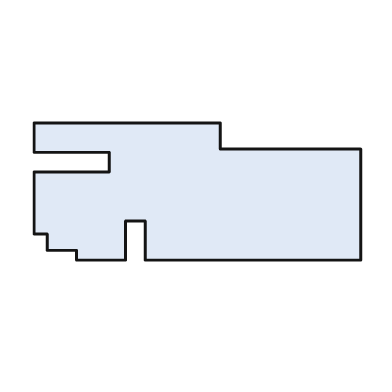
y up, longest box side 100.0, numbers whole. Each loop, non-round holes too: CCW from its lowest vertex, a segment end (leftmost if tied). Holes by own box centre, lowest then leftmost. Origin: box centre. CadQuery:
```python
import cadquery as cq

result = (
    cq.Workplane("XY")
    .moveTo(-37.0, -21.0)
    .lineTo(-22.0, -21.0)
    .lineTo(-22.0, -9.0)
    .lineTo(-16.0, -9.0)
    .lineTo(-16.0, -21.0)
    .lineTo(50.0, -21.0)
    .lineTo(50.0, 13.0)
    .lineTo(7.0, 13.0)
    .lineTo(7.0, 21.0)
    .lineTo(-50.0, 21.0)
    .lineTo(-50.0, 12.0)
    .lineTo(-27.0, 12.0)
    .lineTo(-27.0, 6.0)
    .lineTo(-50.0, 6.0)
    .lineTo(-50.0, -13.0)
    .lineTo(-46.0, -13.0)
    .lineTo(-46.0, -18.0)
    .lineTo(-37.0, -18.0)
    .close()
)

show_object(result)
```